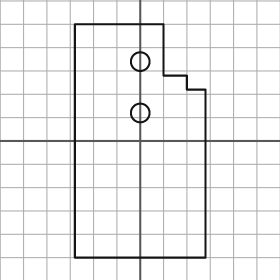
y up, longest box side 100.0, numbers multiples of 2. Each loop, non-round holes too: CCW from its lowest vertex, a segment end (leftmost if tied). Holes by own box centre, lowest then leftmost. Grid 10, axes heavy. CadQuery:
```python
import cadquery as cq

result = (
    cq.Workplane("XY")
    .moveTo(-28.0, -50.0)
    .lineTo(28.0, -50.0)
    .lineTo(28.0, 22.0)
    .lineTo(20.0, 22.0)
    .lineTo(20.0, 28.0)
    .lineTo(10.0, 28.0)
    .lineTo(10.0, 50.0)
    .lineTo(-28.0, 50.0)
    .close()
    .moveTo(0.0, 12.0)
    .circle(4.0)
    .moveTo(0.0, 34.0)
    .circle(4.0)
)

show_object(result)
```